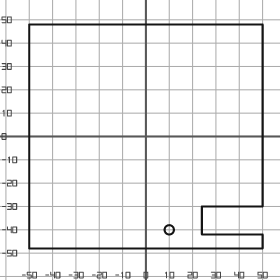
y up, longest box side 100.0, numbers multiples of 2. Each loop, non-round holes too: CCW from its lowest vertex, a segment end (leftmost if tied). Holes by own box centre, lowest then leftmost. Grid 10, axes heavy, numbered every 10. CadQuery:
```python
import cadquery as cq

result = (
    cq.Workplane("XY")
    .moveTo(-50.0, -48.0)
    .lineTo(50.0, -48.0)
    .lineTo(50.0, -42.0)
    .lineTo(24.0, -42.0)
    .lineTo(24.0, -30.0)
    .lineTo(50.0, -30.0)
    .lineTo(50.0, 48.0)
    .lineTo(-50.0, 48.0)
    .close()
    .moveTo(10.0, -40.0)
    .circle(2.0)
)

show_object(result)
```